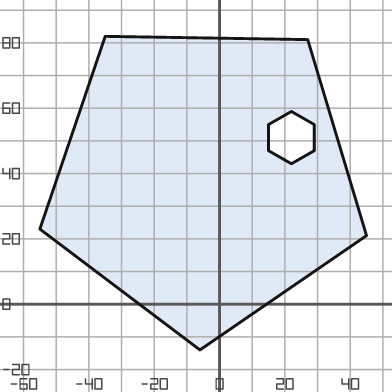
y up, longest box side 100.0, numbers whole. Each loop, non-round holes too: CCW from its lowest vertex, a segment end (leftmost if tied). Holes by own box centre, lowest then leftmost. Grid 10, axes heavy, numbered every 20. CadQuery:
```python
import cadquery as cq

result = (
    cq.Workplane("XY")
    .moveTo(-6.0, -14.0)
    .lineTo(45.0, 21.0)
    .lineTo(27.0, 81.0)
    .lineTo(-35.0, 82.0)
    .lineTo(-55.0, 23.0)
    .close()
    .moveTo(22.0, 43.0)
    .lineTo(29.0, 47.0)
    .lineTo(29.0, 55.0)
    .lineTo(22.0, 59.0)
    .lineTo(15.0, 55.0)
    .lineTo(15.0, 47.0)
    .close()
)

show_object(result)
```